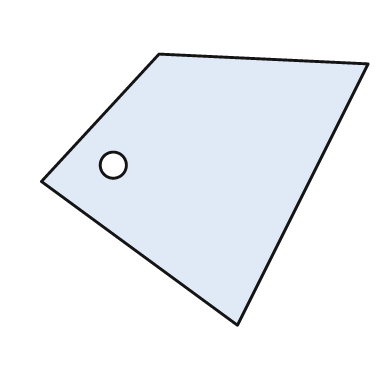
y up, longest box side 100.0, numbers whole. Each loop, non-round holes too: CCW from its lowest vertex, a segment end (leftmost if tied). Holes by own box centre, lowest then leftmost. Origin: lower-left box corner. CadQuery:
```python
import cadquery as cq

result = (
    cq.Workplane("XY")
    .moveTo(60.0, 0.0)
    .lineTo(100.0, 80.0)
    .lineTo(36.0, 83.0)
    .lineTo(0.0, 44.0)
    .close()
    .moveTo(22.0, 49.0)
    .circle(4.0)
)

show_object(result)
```